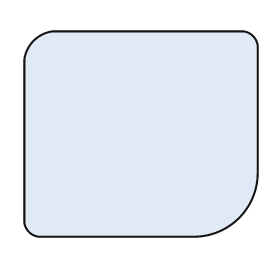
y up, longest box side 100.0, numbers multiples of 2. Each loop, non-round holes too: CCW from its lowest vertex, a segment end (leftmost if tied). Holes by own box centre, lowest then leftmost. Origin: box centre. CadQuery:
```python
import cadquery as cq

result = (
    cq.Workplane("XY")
    .moveTo(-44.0, -44.0)
    .lineTo(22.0, -44.0)
    .threePointArc((42.0, -36.0), (50.0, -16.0))
    .lineTo(50.0, 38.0)
    .threePointArc((48.0, 42.0), (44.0, 44.0))
    .lineTo(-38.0, 44.0)
    .threePointArc((-46.0, 40.0), (-50.0, 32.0))
    .lineTo(-50.0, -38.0)
    .threePointArc((-48.0, -42.0), (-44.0, -44.0))
    .close()
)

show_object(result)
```